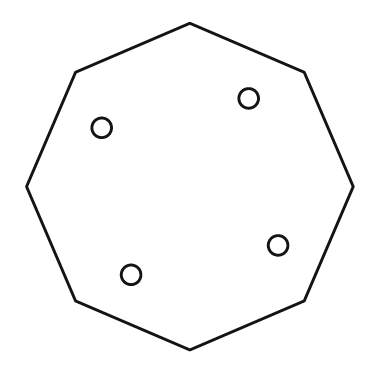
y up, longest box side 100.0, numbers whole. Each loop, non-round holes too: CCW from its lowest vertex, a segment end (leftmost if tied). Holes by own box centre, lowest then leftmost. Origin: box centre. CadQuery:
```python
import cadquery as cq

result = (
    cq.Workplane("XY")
    .moveTo(0.0, -50.0)
    .lineTo(35.0, -35.0)
    .lineTo(50.0, 0.0)
    .lineTo(35.0, 35.0)
    .lineTo(0.0, 50.0)
    .lineTo(-35.0, 35.0)
    .lineTo(-50.0, 0.0)
    .lineTo(-35.0, -35.0)
    .close()
    .moveTo(-18.0, -27.0)
    .circle(3.0)
    .moveTo(27.0, -18.0)
    .circle(3.0)
    .moveTo(-27.0, 18.0)
    .circle(3.0)
    .moveTo(18.0, 27.0)
    .circle(3.0)
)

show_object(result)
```